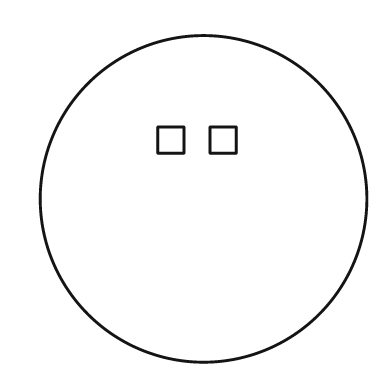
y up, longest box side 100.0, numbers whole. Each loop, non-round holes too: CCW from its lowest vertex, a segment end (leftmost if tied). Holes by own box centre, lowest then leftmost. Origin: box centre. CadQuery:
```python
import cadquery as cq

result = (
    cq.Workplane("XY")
    .moveTo(0.0, 0.0)
    .circle(50.0)
    .moveTo(-14.0, 14.0)
    .lineTo(-6.0, 14.0)
    .lineTo(-6.0, 22.0)
    .lineTo(-14.0, 22.0)
    .close()
    .moveTo(2.0, 14.0)
    .lineTo(10.0, 14.0)
    .lineTo(10.0, 22.0)
    .lineTo(2.0, 22.0)
    .close()
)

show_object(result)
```